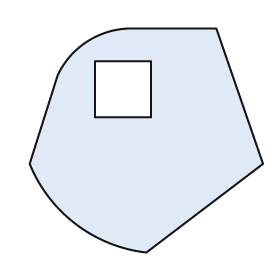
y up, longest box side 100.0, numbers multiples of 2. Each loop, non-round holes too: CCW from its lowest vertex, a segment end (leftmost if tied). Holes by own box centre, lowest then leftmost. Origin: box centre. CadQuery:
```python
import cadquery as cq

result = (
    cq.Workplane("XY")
    .moveTo(0.0, -48.0)
    .lineTo(50.0, -10.0)
    .lineTo(30.0, 48.0)
    .lineTo(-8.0, 48.0)
    .threePointArc((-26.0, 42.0), (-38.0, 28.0))
    .lineTo(-50.0, -10.0)
    .threePointArc((-30.0, -36.0), (0.0, -48.0))
    .close()
    .moveTo(-22.0, 10.0)
    .lineTo(2.0, 10.0)
    .lineTo(2.0, 34.0)
    .lineTo(-22.0, 34.0)
    .close()
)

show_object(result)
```